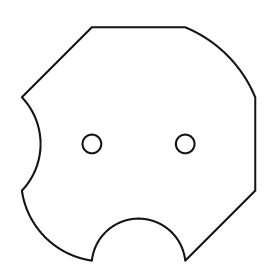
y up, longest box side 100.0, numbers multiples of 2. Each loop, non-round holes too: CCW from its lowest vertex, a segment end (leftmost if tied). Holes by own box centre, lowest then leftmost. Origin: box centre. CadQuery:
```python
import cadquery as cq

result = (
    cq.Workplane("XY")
    .moveTo(-20.0, -50.0)
    .threePointArc((0.0, -32.0), (20.0, -50.0))
    .lineTo(50.0, -20.0)
    .lineTo(50.0, 20.0)
    .threePointArc((38.0, 38.0), (20.0, 50.0))
    .lineTo(-20.0, 50.0)
    .lineTo(-50.0, 20.0)
    .threePointArc((-42.0, 0.0), (-50.0, -20.0))
    .threePointArc((-40.0, -40.0), (-20.0, -50.0))
    .close()
    .moveTo(-20.0, 0.0)
    .circle(4.0)
    .moveTo(20.0, 0.0)
    .circle(4.0)
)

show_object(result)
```